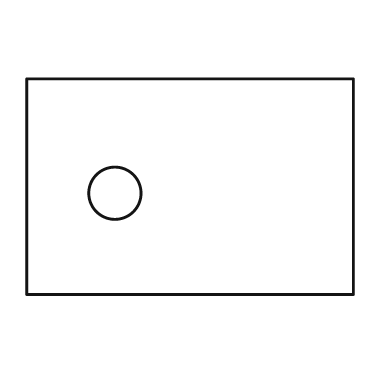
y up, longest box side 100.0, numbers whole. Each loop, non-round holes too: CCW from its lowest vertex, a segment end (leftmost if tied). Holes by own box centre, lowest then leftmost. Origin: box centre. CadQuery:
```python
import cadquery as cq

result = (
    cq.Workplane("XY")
    .moveTo(-50.0, -33.0)
    .lineTo(50.0, -33.0)
    .lineTo(50.0, 33.0)
    .lineTo(-50.0, 33.0)
    .close()
    .moveTo(-23.0, -2.0)
    .circle(8.0)
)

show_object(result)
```